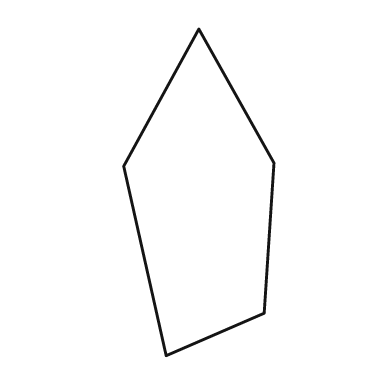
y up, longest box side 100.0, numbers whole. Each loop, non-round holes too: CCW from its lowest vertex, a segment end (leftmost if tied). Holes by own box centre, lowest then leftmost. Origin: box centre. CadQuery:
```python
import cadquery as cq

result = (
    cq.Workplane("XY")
    .moveTo(-10.0, -50.0)
    .lineTo(20.0, -37.0)
    .lineTo(23.0, 9.0)
    .lineTo(0.0, 50.0)
    .lineTo(-23.0, 8.0)
    .close()
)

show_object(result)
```